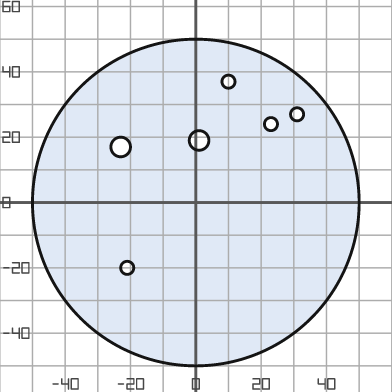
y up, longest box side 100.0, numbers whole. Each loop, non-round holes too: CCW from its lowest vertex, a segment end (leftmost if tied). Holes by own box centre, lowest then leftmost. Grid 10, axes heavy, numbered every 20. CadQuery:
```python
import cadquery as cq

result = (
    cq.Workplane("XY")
    .moveTo(0.0, 0.0)
    .circle(50.0)
    .moveTo(-21.0, -20.0)
    .circle(2.0)
    .moveTo(-23.0, 17.0)
    .circle(3.0)
    .moveTo(1.0, 19.0)
    .circle(3.0)
    .moveTo(23.0, 24.0)
    .circle(2.0)
    .moveTo(31.0, 27.0)
    .circle(2.0)
    .moveTo(10.0, 37.0)
    .circle(2.0)
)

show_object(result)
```